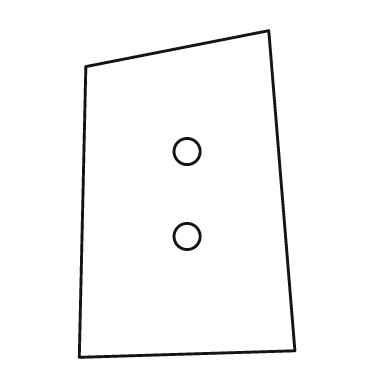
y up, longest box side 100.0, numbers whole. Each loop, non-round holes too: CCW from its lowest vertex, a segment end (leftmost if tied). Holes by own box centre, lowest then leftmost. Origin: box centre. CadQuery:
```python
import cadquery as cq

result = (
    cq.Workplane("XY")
    .moveTo(-33.0, -50.0)
    .lineTo(33.0, -48.0)
    .lineTo(25.0, 50.0)
    .lineTo(-31.0, 39.0)
    .close()
    .moveTo(0.0, -13.0)
    .circle(4.0)
    .moveTo(0.0, 13.0)
    .circle(4.0)
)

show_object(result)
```